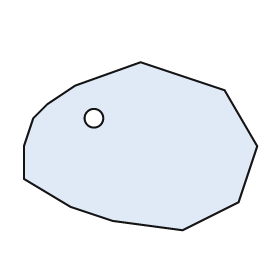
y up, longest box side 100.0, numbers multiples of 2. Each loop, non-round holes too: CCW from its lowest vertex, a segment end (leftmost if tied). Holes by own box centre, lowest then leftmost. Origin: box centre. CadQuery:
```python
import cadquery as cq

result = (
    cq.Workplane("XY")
    .moveTo(18.0, -36.0)
    .lineTo(42.0, -24.0)
    .lineTo(50.0, 0.0)
    .lineTo(36.0, 24.0)
    .lineTo(0.0, 36.0)
    .lineTo(-28.0, 26.0)
    .lineTo(-40.0, 18.0)
    .lineTo(-46.0, 12.0)
    .lineTo(-50.0, 0.0)
    .lineTo(-50.0, -14.0)
    .lineTo(-30.0, -26.0)
    .lineTo(-12.0, -32.0)
    .close()
    .moveTo(-20.0, 12.0)
    .circle(4.0)
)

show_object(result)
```